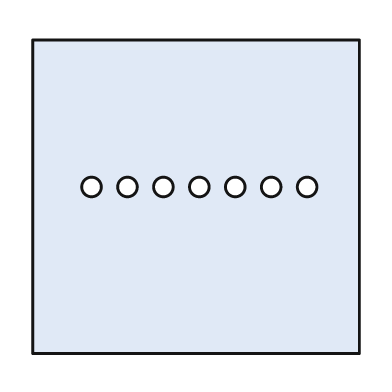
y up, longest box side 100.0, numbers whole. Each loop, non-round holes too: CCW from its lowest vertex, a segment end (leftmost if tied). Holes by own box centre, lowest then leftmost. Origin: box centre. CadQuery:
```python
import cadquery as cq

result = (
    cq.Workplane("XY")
    .moveTo(-50.0, -48.0)
    .lineTo(50.0, -48.0)
    .lineTo(50.0, 48.0)
    .lineTo(-50.0, 48.0)
    .close()
    .moveTo(-32.0, 3.0)
    .circle(3.0)
    .moveTo(-21.0, 3.0)
    .circle(3.0)
    .moveTo(-10.0, 3.0)
    .circle(3.0)
    .moveTo(1.0, 3.0)
    .circle(3.0)
    .moveTo(12.0, 3.0)
    .circle(3.0)
    .moveTo(23.0, 3.0)
    .circle(3.0)
    .moveTo(34.0, 3.0)
    .circle(3.0)
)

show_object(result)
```